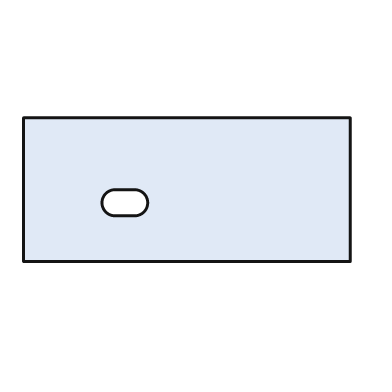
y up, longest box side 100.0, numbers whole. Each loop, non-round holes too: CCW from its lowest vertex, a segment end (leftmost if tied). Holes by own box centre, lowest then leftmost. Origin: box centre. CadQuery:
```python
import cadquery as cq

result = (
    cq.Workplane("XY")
    .moveTo(-50.0, -22.0)
    .lineTo(50.0, -22.0)
    .lineTo(50.0, 22.0)
    .lineTo(-50.0, 22.0)
    .close()
    .moveTo(-22.0, -8.0)
    .lineTo(-16.0, -8.0)
    .threePointArc((-12.0, -4.0), (-16.0, 0.0))
    .lineTo(-22.0, 0.0)
    .threePointArc((-26.0, -4.0), (-22.0, -8.0))
    .close()
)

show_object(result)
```